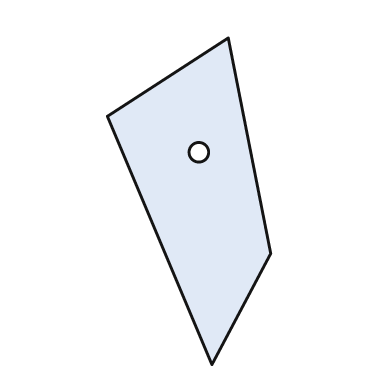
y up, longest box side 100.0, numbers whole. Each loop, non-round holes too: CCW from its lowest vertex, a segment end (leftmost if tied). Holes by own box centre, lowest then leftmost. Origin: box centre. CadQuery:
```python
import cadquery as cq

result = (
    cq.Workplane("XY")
    .moveTo(7.0, -50.0)
    .lineTo(25.0, -16.0)
    .lineTo(12.0, 50.0)
    .lineTo(-25.0, 26.0)
    .close()
    .moveTo(3.0, 15.0)
    .circle(3.0)
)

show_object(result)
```